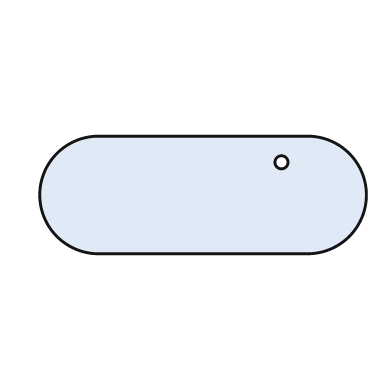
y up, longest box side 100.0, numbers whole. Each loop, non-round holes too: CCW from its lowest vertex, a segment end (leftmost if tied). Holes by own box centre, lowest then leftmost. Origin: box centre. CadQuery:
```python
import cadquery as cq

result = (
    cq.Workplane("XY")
    .moveTo(-32.0, -18.0)
    .lineTo(32.0, -18.0)
    .threePointArc((50.0, 0.0), (32.0, 18.0))
    .lineTo(-32.0, 18.0)
    .threePointArc((-50.0, 0.0), (-32.0, -18.0))
    .close()
    .moveTo(24.0, 10.0)
    .circle(2.0)
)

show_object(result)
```